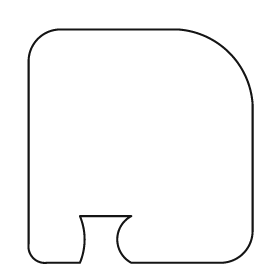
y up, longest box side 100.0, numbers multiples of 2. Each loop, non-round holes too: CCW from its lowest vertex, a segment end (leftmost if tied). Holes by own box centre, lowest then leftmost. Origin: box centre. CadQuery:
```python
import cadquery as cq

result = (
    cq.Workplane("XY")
    .moveTo(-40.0, -50.0)
    .lineTo(-26.0, -50.0)
    .threePointArc((-24.0, -40.0), (-26.0, -30.0))
    .lineTo(-4.0, -30.0)
    .threePointArc((-10.0, -40.0), (-4.0, -50.0))
    .lineTo(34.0, -50.0)
    .threePointArc((44.0, -46.0), (48.0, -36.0))
    .lineTo(48.0, 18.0)
    .threePointArc((38.0, 40.0), (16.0, 50.0))
    .lineTo(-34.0, 50.0)
    .threePointArc((-44.0, 46.0), (-48.0, 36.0))
    .lineTo(-48.0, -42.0)
    .threePointArc((-46.0, -48.0), (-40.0, -50.0))
    .close()
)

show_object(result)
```